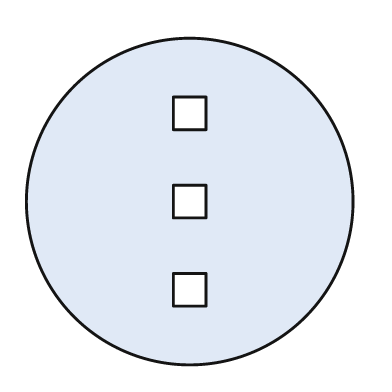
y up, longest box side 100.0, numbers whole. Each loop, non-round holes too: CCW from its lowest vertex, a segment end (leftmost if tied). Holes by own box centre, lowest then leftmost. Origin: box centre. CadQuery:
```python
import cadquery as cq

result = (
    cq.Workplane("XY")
    .moveTo(0.0, 0.0)
    .circle(50.0)
    .moveTo(-5.0, -32.0)
    .lineTo(5.0, -32.0)
    .lineTo(5.0, -22.0)
    .lineTo(-5.0, -22.0)
    .close()
    .moveTo(-5.0, -5.0)
    .lineTo(5.0, -5.0)
    .lineTo(5.0, 5.0)
    .lineTo(-5.0, 5.0)
    .close()
    .moveTo(-5.0, 22.0)
    .lineTo(5.0, 22.0)
    .lineTo(5.0, 32.0)
    .lineTo(-5.0, 32.0)
    .close()
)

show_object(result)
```